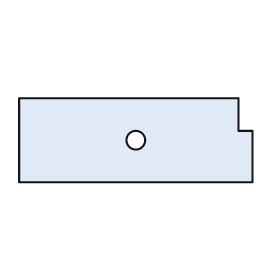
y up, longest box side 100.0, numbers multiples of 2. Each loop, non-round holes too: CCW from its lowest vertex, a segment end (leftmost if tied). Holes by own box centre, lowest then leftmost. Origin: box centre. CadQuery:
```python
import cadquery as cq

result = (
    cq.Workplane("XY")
    .moveTo(-50.0, -18.0)
    .lineTo(50.0, -18.0)
    .lineTo(50.0, 4.0)
    .lineTo(44.0, 4.0)
    .lineTo(44.0, 18.0)
    .lineTo(-50.0, 18.0)
    .close()
    .moveTo(0.0, 0.0)
    .circle(4.0)
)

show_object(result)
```